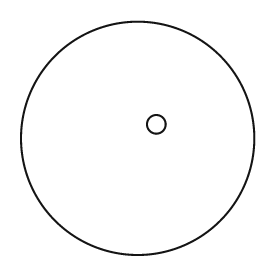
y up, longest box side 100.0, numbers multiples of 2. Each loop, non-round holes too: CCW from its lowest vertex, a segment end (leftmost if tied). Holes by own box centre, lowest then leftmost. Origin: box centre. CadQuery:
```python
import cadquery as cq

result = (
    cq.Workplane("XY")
    .moveTo(0.0, 0.0)
    .circle(50.0)
    .moveTo(8.0, 6.0)
    .circle(4.0)
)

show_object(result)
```